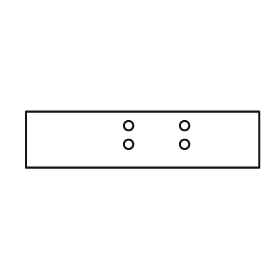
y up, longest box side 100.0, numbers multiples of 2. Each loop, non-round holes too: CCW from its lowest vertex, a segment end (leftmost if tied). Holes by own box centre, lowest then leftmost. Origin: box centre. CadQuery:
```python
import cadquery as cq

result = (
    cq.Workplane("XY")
    .moveTo(-50.0, -12.0)
    .lineTo(50.0, -12.0)
    .lineTo(50.0, 12.0)
    .lineTo(-50.0, 12.0)
    .close()
    .moveTo(-6.0, -2.0)
    .circle(2.0)
    .moveTo(18.0, -2.0)
    .circle(2.0)
    .moveTo(-6.0, 6.0)
    .circle(2.0)
    .moveTo(18.0, 6.0)
    .circle(2.0)
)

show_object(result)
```